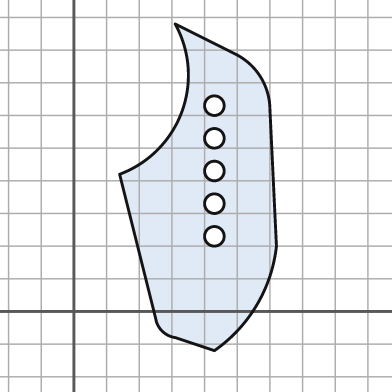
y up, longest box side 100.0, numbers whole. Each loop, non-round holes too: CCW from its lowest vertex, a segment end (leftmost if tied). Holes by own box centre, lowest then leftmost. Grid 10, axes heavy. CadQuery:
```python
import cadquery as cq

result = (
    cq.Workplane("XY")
    .moveTo(43.0, -12.0)
    .threePointArc((56.0, 2.0), (62.0, 20.0))
    .lineTo(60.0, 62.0)
    .threePointArc((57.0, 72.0), (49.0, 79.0))
    .lineTo(31.0, 88.0)
    .threePointArc((33.0, 61.0), (14.0, 42.0))
    .lineTo(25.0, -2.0)
    .threePointArc((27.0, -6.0), (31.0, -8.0))
    .close()
    .moveTo(43.0, 23.0)
    .circle(3.0)
    .moveTo(43.0, 33.0)
    .circle(3.0)
    .moveTo(43.0, 43.0)
    .circle(3.0)
    .moveTo(43.0, 53.0)
    .circle(3.0)
    .moveTo(43.0, 63.0)
    .circle(3.0)
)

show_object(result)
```